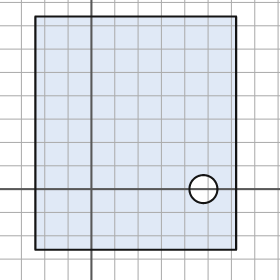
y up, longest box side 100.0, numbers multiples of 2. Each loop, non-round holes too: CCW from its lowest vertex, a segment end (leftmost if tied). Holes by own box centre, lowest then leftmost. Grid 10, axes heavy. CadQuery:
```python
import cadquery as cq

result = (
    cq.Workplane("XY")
    .moveTo(-24.0, -26.0)
    .lineTo(62.0, -26.0)
    .lineTo(62.0, 74.0)
    .lineTo(-24.0, 74.0)
    .close()
    .moveTo(48.0, 0.0)
    .circle(6.0)
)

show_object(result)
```